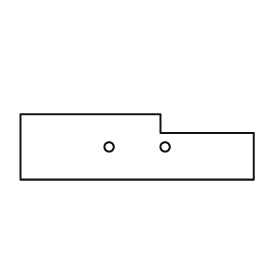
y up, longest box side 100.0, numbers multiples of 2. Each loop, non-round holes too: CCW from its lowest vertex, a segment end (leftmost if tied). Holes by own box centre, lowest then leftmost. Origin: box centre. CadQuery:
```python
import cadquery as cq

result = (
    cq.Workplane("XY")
    .moveTo(-50.0, -14.0)
    .lineTo(50.0, -14.0)
    .lineTo(50.0, 6.0)
    .lineTo(10.0, 6.0)
    .lineTo(10.0, 14.0)
    .lineTo(-50.0, 14.0)
    .close()
    .moveTo(-12.0, 0.0)
    .circle(2.0)
    .moveTo(12.0, 0.0)
    .circle(2.0)
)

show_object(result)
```